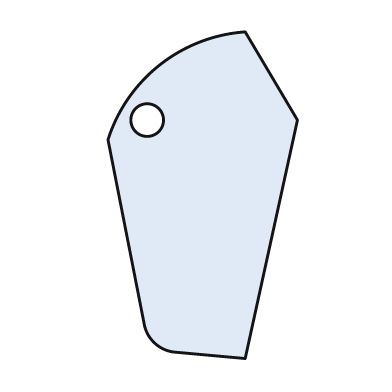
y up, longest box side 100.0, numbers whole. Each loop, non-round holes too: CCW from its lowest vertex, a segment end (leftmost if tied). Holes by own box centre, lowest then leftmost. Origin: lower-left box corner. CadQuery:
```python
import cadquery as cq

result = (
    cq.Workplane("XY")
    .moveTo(42.0, 0.0)
    .lineTo(58.0, 73.0)
    .lineTo(42.0, 100.0)
    .threePointArc((16.0, 90.0), (0.0, 67.0))
    .lineTo(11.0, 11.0)
    .threePointArc((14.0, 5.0), (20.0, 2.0))
    .close()
    .moveTo(12.0, 73.0)
    .circle(5.0)
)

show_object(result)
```